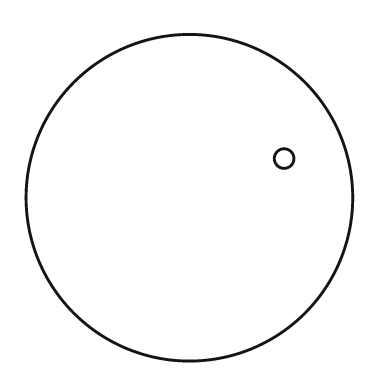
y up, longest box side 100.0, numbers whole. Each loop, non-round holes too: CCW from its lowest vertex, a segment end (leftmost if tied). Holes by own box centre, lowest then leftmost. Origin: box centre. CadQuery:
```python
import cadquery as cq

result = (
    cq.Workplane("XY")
    .moveTo(0.0, 0.0)
    .circle(50.0)
    .moveTo(29.0, 12.0)
    .circle(3.0)
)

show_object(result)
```